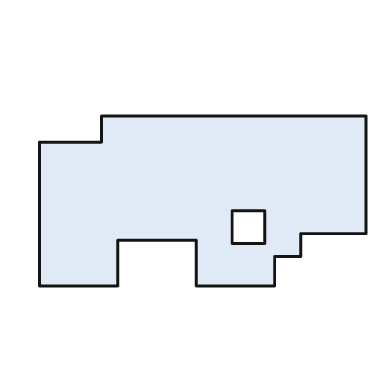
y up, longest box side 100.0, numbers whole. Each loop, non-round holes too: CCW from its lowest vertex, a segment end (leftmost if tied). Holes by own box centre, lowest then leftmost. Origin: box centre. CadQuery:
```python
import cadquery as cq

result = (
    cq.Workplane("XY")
    .moveTo(-50.0, -26.0)
    .lineTo(-26.0, -26.0)
    .lineTo(-26.0, -12.0)
    .lineTo(-2.0, -12.0)
    .lineTo(-2.0, -26.0)
    .lineTo(22.0, -26.0)
    .lineTo(22.0, -17.0)
    .lineTo(30.0, -17.0)
    .lineTo(30.0, -10.0)
    .lineTo(50.0, -10.0)
    .lineTo(50.0, 26.0)
    .lineTo(-31.0, 26.0)
    .lineTo(-31.0, 18.0)
    .lineTo(-50.0, 18.0)
    .close()
    .moveTo(9.0, -13.0)
    .lineTo(19.0, -13.0)
    .lineTo(19.0, -3.0)
    .lineTo(9.0, -3.0)
    .close()
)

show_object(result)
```